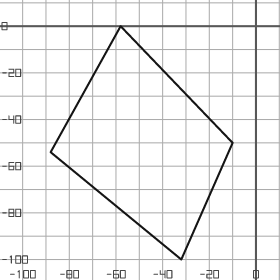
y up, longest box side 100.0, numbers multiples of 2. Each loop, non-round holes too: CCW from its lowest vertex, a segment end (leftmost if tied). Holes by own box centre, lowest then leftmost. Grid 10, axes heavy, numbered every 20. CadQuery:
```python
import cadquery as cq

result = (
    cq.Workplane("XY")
    .moveTo(-32.0, -100.0)
    .lineTo(-10.0, -50.0)
    .lineTo(-58.0, 0.0)
    .lineTo(-88.0, -54.0)
    .close()
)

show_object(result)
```